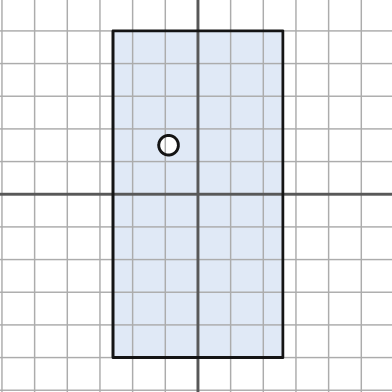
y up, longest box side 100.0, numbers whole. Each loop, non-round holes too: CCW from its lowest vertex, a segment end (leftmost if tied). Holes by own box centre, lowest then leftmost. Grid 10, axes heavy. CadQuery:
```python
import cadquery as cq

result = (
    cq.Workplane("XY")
    .moveTo(-26.0, -50.0)
    .lineTo(26.0, -50.0)
    .lineTo(26.0, 50.0)
    .lineTo(-26.0, 50.0)
    .close()
    .moveTo(-9.0, 15.0)
    .circle(3.0)
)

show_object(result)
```